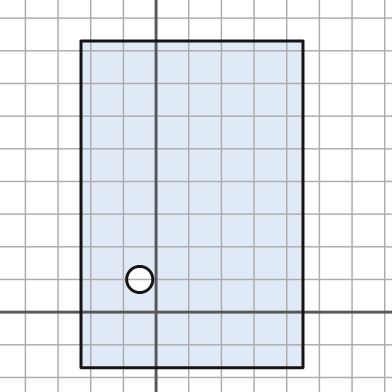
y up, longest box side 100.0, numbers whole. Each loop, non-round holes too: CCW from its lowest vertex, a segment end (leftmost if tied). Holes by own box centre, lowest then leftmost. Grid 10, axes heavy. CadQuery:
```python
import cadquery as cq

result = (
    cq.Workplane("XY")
    .moveTo(-23.0, -17.0)
    .lineTo(45.0, -17.0)
    .lineTo(45.0, 83.0)
    .lineTo(-23.0, 83.0)
    .close()
    .moveTo(-5.0, 10.0)
    .circle(4.0)
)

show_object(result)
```